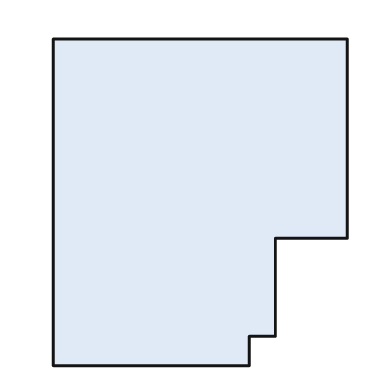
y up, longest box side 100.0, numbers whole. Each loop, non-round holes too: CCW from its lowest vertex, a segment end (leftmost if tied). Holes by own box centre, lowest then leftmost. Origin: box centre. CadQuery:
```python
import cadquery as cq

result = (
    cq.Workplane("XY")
    .moveTo(-45.0, -50.0)
    .lineTo(15.0, -50.0)
    .lineTo(15.0, -41.0)
    .lineTo(23.0, -41.0)
    .lineTo(23.0, -11.0)
    .lineTo(45.0, -11.0)
    .lineTo(45.0, 50.0)
    .lineTo(-45.0, 50.0)
    .close()
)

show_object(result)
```